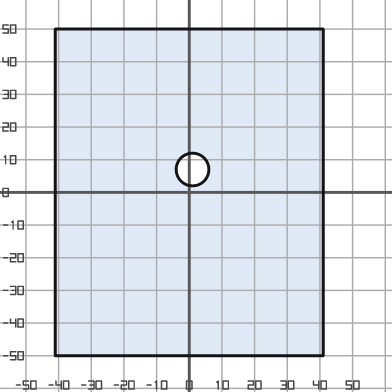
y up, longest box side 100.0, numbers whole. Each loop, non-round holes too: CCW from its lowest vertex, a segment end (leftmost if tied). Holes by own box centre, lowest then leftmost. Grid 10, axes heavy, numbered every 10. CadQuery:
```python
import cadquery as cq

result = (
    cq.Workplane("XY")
    .moveTo(-41.0, -50.0)
    .lineTo(41.0, -50.0)
    .lineTo(41.0, 50.0)
    .lineTo(-41.0, 50.0)
    .close()
    .moveTo(1.0, 7.0)
    .circle(5.0)
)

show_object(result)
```